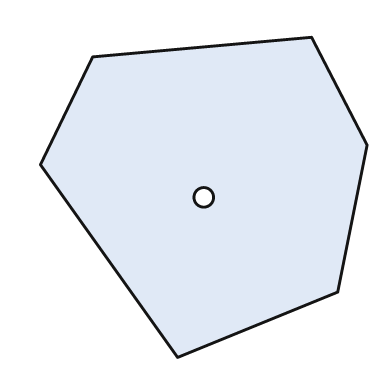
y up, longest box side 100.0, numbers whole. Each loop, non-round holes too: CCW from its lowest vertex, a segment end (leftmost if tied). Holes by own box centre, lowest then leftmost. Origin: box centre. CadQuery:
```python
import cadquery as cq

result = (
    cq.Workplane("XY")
    .moveTo(-8.0, -49.0)
    .lineTo(41.0, -29.0)
    .lineTo(50.0, 16.0)
    .lineTo(33.0, 49.0)
    .lineTo(-34.0, 43.0)
    .lineTo(-50.0, 10.0)
    .close()
    .moveTo(0.0, 0.0)
    .circle(3.0)
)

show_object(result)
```